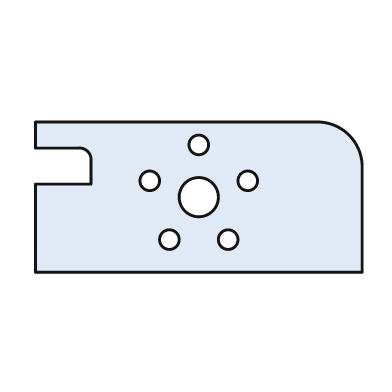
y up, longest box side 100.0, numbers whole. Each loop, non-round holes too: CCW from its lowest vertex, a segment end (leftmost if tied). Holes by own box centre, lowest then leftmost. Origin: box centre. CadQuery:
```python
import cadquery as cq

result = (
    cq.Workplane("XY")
    .moveTo(-50.0, -23.0)
    .lineTo(50.0, -23.0)
    .lineTo(50.0, 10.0)
    .threePointArc((46.0, 19.0), (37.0, 23.0))
    .lineTo(-50.0, 23.0)
    .lineTo(-50.0, 15.0)
    .lineTo(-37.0, 15.0)
    .threePointArc((-34.0, 14.0), (-33.0, 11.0))
    .lineTo(-33.0, 4.0)
    .lineTo(-50.0, 4.0)
    .close()
    .moveTo(-9.0, -13.0)
    .circle(3.0)
    .moveTo(9.0, -13.0)
    .circle(3.0)
    .moveTo(0.0, 0.0)
    .circle(6.0)
    .moveTo(-15.0, 5.0)
    .circle(3.0)
    .moveTo(15.0, 5.0)
    .circle(3.0)
    .moveTo(0.0, 16.0)
    .circle(3.0)
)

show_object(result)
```